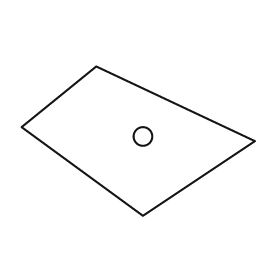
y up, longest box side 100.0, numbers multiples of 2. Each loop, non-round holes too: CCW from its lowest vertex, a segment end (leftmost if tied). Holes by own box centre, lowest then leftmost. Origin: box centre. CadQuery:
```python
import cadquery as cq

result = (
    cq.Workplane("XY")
    .moveTo(2.0, -32.0)
    .lineTo(50.0, 0.0)
    .lineTo(-18.0, 32.0)
    .lineTo(-50.0, 6.0)
    .close()
    .moveTo(2.0, 2.0)
    .circle(4.0)
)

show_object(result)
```